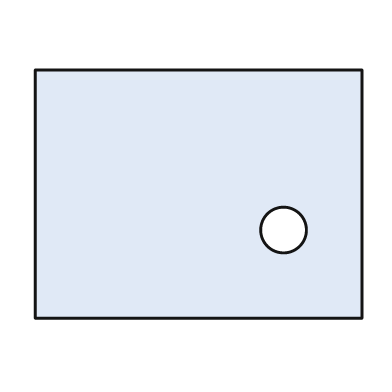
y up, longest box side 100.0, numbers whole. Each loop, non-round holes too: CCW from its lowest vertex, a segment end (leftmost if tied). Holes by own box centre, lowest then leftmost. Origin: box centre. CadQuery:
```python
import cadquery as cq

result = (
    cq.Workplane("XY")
    .moveTo(-50.0, -38.0)
    .lineTo(50.0, -38.0)
    .lineTo(50.0, 38.0)
    .lineTo(-50.0, 38.0)
    .close()
    .moveTo(26.0, -11.0)
    .circle(7.0)
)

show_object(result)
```